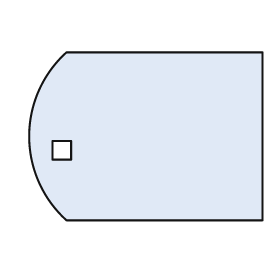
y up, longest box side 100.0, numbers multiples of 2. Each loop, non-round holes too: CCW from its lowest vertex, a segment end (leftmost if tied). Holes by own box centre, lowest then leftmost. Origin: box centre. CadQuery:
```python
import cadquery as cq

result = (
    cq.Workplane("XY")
    .moveTo(-34.0, -36.0)
    .lineTo(50.0, -36.0)
    .lineTo(50.0, 36.0)
    .lineTo(-34.0, 36.0)
    .threePointArc((-50.0, 0.0), (-34.0, -36.0))
    .close()
    .moveTo(-40.0, -10.0)
    .lineTo(-32.0, -10.0)
    .lineTo(-32.0, -2.0)
    .lineTo(-40.0, -2.0)
    .close()
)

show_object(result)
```